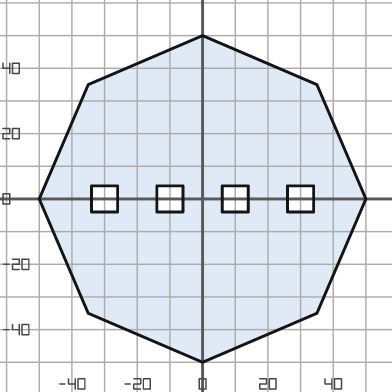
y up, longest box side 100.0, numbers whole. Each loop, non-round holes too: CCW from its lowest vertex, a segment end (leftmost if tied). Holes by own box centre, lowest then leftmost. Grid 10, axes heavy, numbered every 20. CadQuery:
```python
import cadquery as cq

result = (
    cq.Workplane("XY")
    .moveTo(0.0, -50.0)
    .lineTo(35.0, -35.0)
    .lineTo(50.0, 0.0)
    .lineTo(35.0, 35.0)
    .lineTo(0.0, 50.0)
    .lineTo(-35.0, 35.0)
    .lineTo(-50.0, 0.0)
    .lineTo(-35.0, -35.0)
    .close()
    .moveTo(-34.0, -4.0)
    .lineTo(-26.0, -4.0)
    .lineTo(-26.0, 4.0)
    .lineTo(-34.0, 4.0)
    .close()
    .moveTo(-14.0, -4.0)
    .lineTo(-6.0, -4.0)
    .lineTo(-6.0, 4.0)
    .lineTo(-14.0, 4.0)
    .close()
    .moveTo(6.0, -4.0)
    .lineTo(14.0, -4.0)
    .lineTo(14.0, 4.0)
    .lineTo(6.0, 4.0)
    .close()
    .moveTo(26.0, -4.0)
    .lineTo(34.0, -4.0)
    .lineTo(34.0, 4.0)
    .lineTo(26.0, 4.0)
    .close()
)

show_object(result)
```